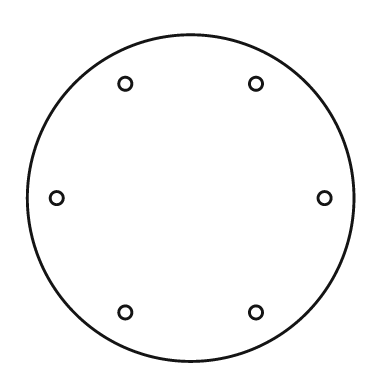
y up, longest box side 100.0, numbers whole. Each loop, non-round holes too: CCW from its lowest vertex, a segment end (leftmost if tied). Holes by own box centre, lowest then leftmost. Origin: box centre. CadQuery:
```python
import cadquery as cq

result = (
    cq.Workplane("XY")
    .moveTo(0.0, 0.0)
    .circle(50.0)
    .moveTo(-20.0, -35.0)
    .circle(2.0)
    .moveTo(20.0, -35.0)
    .circle(2.0)
    .moveTo(-41.0, 0.0)
    .circle(2.0)
    .moveTo(41.0, 0.0)
    .circle(2.0)
    .moveTo(-20.0, 35.0)
    .circle(2.0)
    .moveTo(20.0, 35.0)
    .circle(2.0)
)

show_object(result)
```